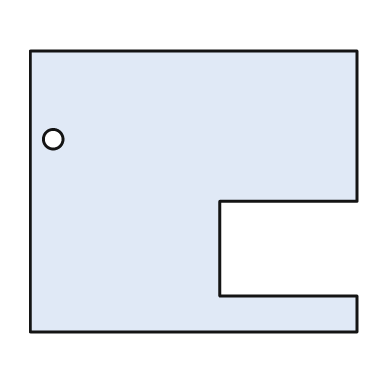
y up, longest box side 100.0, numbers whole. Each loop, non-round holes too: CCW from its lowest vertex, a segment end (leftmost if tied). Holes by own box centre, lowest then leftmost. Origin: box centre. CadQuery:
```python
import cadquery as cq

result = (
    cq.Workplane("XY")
    .moveTo(-50.0, -43.0)
    .lineTo(50.0, -43.0)
    .lineTo(50.0, -32.0)
    .lineTo(8.0, -32.0)
    .lineTo(8.0, -3.0)
    .lineTo(50.0, -3.0)
    .lineTo(50.0, 43.0)
    .lineTo(-50.0, 43.0)
    .close()
    .moveTo(-43.0, 16.0)
    .circle(3.0)
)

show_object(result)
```